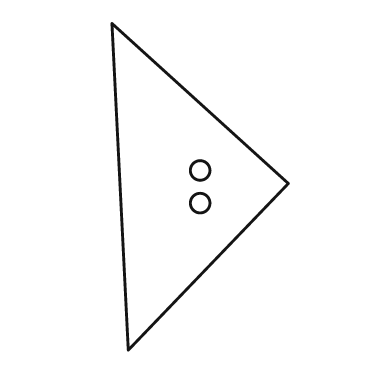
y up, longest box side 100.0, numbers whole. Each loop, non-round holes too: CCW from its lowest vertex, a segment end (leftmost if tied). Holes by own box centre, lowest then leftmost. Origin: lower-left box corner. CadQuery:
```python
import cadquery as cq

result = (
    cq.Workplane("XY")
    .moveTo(5.0, 0.0)
    .lineTo(54.0, 51.0)
    .lineTo(0.0, 100.0)
    .close()
    .moveTo(27.0, 45.0)
    .circle(3.0)
    .moveTo(27.0, 55.0)
    .circle(3.0)
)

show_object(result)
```